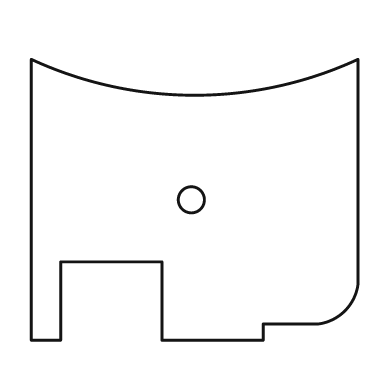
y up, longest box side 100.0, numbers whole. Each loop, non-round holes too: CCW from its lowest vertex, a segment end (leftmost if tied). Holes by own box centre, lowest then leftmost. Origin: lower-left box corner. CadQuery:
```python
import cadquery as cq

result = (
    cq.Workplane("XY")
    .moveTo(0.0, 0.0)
    .lineTo(9.0, 0.0)
    .lineTo(9.0, 24.0)
    .lineTo(40.0, 24.0)
    .lineTo(40.0, 0.0)
    .lineTo(71.0, 0.0)
    .lineTo(71.0, 5.0)
    .lineTo(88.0, 5.0)
    .threePointArc((96.0, 9.0), (100.0, 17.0))
    .lineTo(100.0, 86.0)
    .threePointArc((50.0, 75.0), (0.0, 86.0))
    .close()
    .moveTo(49.0, 43.0)
    .circle(4.0)
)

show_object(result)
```